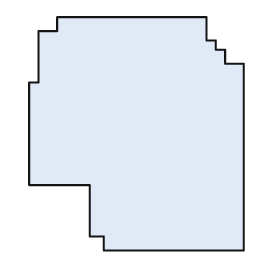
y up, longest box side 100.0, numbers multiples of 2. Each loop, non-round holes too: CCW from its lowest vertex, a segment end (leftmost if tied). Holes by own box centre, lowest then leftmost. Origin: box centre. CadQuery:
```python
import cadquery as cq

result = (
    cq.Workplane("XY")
    .moveTo(-14.0, -50.0)
    .lineTo(46.0, -50.0)
    .lineTo(46.0, 30.0)
    .lineTo(38.0, 30.0)
    .lineTo(38.0, 36.0)
    .lineTo(34.0, 36.0)
    .lineTo(34.0, 40.0)
    .lineTo(30.0, 40.0)
    .lineTo(30.0, 50.0)
    .lineTo(-34.0, 50.0)
    .lineTo(-34.0, 44.0)
    .lineTo(-42.0, 44.0)
    .lineTo(-42.0, 22.0)
    .lineTo(-46.0, 22.0)
    .lineTo(-46.0, -22.0)
    .lineTo(-20.0, -22.0)
    .lineTo(-20.0, -44.0)
    .lineTo(-14.0, -44.0)
    .close()
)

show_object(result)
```